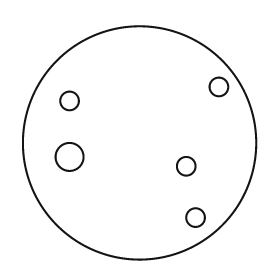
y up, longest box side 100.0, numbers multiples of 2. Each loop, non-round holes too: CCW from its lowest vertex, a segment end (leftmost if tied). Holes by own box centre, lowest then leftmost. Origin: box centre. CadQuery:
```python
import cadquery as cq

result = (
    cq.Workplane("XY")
    .moveTo(0.0, 0.0)
    .circle(50.0)
    .moveTo(24.0, -32.0)
    .circle(4.0)
    .moveTo(20.0, -10.0)
    .circle(4.0)
    .moveTo(-30.0, -6.0)
    .circle(6.0)
    .moveTo(-30.0, 18.0)
    .circle(4.0)
    .moveTo(34.0, 24.0)
    .circle(4.0)
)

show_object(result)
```